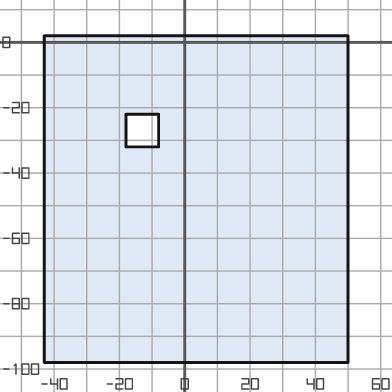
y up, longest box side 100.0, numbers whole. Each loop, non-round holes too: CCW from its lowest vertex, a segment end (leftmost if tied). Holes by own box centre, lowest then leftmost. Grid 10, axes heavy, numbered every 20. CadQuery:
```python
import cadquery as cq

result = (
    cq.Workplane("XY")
    .moveTo(-43.0, -98.0)
    .lineTo(50.0, -98.0)
    .lineTo(50.0, 2.0)
    .lineTo(-43.0, 2.0)
    .close()
    .moveTo(-18.0, -32.0)
    .lineTo(-8.0, -32.0)
    .lineTo(-8.0, -22.0)
    .lineTo(-18.0, -22.0)
    .close()
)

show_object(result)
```